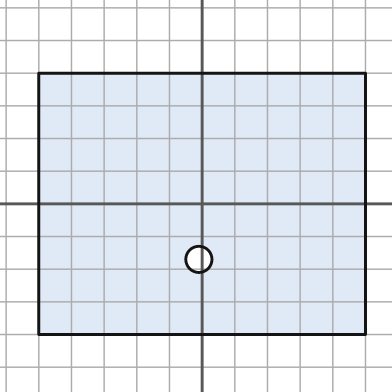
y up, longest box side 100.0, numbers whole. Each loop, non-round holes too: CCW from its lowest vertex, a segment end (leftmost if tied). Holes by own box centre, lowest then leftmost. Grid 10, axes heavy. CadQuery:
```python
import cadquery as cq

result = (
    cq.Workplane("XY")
    .moveTo(-50.0, -40.0)
    .lineTo(50.0, -40.0)
    .lineTo(50.0, 40.0)
    .lineTo(-50.0, 40.0)
    .close()
    .moveTo(-1.0, -17.0)
    .circle(4.0)
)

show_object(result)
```